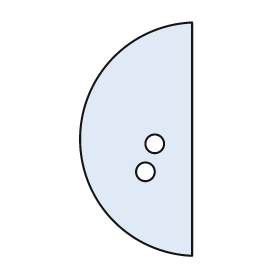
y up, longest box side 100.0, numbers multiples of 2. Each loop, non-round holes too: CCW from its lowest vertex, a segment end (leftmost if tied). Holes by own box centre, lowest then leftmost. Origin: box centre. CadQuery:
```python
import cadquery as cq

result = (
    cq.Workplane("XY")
    .moveTo(24.0, -50.0)
    .lineTo(24.0, 50.0)
    .threePointArc((-24.0, 0.0), (24.0, -50.0))
    .close()
    .moveTo(4.0, -14.0)
    .circle(4.0)
    .moveTo(8.0, -2.0)
    .circle(4.0)
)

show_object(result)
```